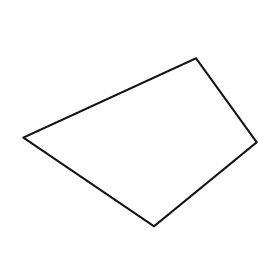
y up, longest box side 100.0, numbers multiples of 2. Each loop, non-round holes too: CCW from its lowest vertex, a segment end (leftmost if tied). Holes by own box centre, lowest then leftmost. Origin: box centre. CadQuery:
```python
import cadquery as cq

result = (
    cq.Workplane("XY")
    .moveTo(6.0, -36.0)
    .lineTo(50.0, 0.0)
    .lineTo(24.0, 36.0)
    .lineTo(-50.0, 2.0)
    .close()
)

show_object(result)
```